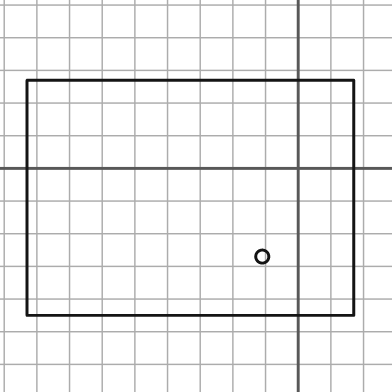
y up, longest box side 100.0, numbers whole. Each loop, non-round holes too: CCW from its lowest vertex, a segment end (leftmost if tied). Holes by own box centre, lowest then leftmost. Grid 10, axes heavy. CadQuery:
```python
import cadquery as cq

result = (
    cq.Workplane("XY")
    .moveTo(-83.0, -45.0)
    .lineTo(17.0, -45.0)
    .lineTo(17.0, 27.0)
    .lineTo(-83.0, 27.0)
    .close()
    .moveTo(-11.0, -27.0)
    .circle(2.0)
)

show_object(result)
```